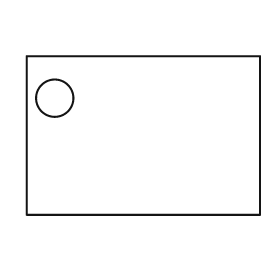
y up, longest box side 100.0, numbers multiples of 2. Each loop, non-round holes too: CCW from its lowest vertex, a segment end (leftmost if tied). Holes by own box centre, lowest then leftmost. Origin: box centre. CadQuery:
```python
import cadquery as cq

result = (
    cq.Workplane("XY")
    .moveTo(-50.0, -34.0)
    .lineTo(50.0, -34.0)
    .lineTo(50.0, 34.0)
    .lineTo(-50.0, 34.0)
    .close()
    .moveTo(-38.0, 16.0)
    .circle(8.0)
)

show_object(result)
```